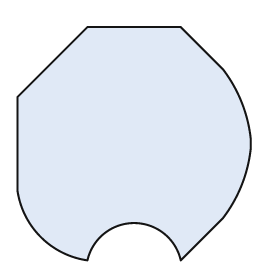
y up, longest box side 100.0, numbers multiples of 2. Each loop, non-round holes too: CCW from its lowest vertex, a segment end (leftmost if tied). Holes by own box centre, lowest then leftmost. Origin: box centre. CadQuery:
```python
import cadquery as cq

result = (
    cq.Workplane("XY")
    .moveTo(-20.0, -50.0)
    .threePointArc((0.0, -34.0), (20.0, -50.0))
    .lineTo(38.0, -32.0)
    .threePointArc((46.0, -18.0), (50.0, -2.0))
    .lineTo(50.0, 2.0)
    .threePointArc((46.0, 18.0), (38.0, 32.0))
    .lineTo(20.0, 50.0)
    .lineTo(-20.0, 50.0)
    .lineTo(-50.0, 20.0)
    .lineTo(-50.0, -20.0)
    .threePointArc((-40.0, -40.0), (-20.0, -50.0))
    .close()
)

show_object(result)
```